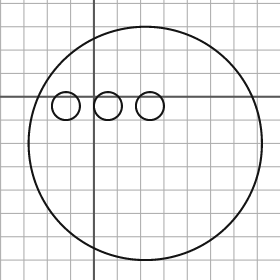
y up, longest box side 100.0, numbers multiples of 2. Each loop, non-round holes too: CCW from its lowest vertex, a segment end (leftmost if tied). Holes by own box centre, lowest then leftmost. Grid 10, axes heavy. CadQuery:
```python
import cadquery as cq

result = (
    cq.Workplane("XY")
    .moveTo(22.0, -20.0)
    .circle(50.0)
    .moveTo(-12.0, -4.0)
    .circle(6.0)
    .moveTo(6.0, -4.0)
    .circle(6.0)
    .moveTo(24.0, -4.0)
    .circle(6.0)
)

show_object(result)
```